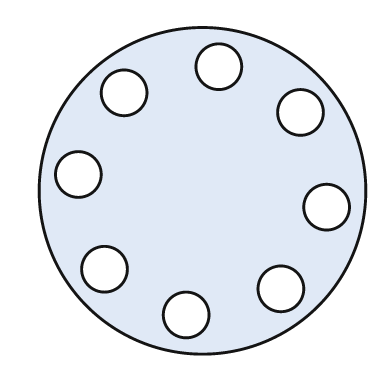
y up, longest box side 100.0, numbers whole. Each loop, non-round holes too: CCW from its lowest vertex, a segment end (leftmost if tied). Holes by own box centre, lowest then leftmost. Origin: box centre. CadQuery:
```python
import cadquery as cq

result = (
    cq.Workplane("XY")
    .moveTo(0.0, 0.0)
    .circle(50.0)
    .moveTo(-5.0, -38.0)
    .circle(7.0)
    .moveTo(24.0, -30.0)
    .circle(7.0)
    .moveTo(-30.0, -24.0)
    .circle(7.0)
    .moveTo(38.0, -5.0)
    .circle(7.0)
    .moveTo(-38.0, 5.0)
    .circle(7.0)
    .moveTo(30.0, 24.0)
    .circle(7.0)
    .moveTo(-24.0, 30.0)
    .circle(7.0)
    .moveTo(5.0, 38.0)
    .circle(7.0)
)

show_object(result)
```